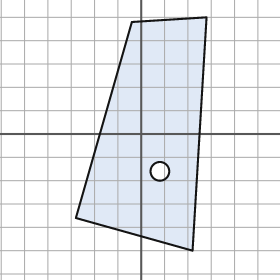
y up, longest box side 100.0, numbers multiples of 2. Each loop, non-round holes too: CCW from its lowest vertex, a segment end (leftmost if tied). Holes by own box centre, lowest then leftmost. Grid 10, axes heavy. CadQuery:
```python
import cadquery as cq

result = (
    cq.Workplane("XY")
    .moveTo(22.0, -50.0)
    .lineTo(28.0, 50.0)
    .lineTo(-4.0, 48.0)
    .lineTo(-28.0, -36.0)
    .close()
    .moveTo(8.0, -16.0)
    .circle(4.0)
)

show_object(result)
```